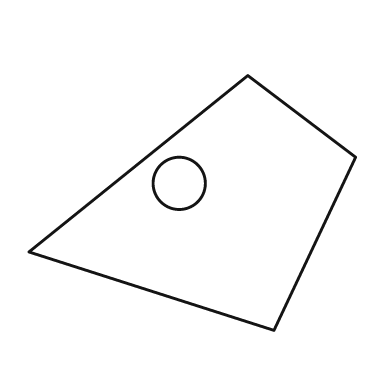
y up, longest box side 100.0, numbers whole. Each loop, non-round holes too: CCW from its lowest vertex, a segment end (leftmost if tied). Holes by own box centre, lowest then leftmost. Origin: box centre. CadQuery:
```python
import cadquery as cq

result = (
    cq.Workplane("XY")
    .moveTo(25.0, -39.0)
    .lineTo(50.0, 14.0)
    .lineTo(17.0, 39.0)
    .lineTo(-50.0, -15.0)
    .close()
    .moveTo(-4.0, 6.0)
    .circle(8.0)
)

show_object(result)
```